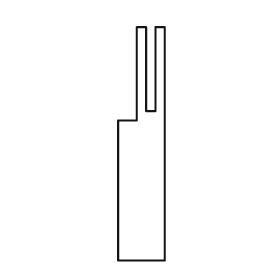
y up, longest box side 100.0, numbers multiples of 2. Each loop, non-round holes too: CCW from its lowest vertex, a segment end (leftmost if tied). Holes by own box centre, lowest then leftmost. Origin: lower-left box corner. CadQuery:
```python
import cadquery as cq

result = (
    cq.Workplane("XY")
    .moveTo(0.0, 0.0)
    .lineTo(20.0, 0.0)
    .lineTo(20.0, 100.0)
    .lineTo(16.0, 100.0)
    .lineTo(16.0, 64.0)
    .lineTo(12.0, 64.0)
    .lineTo(12.0, 100.0)
    .lineTo(8.0, 100.0)
    .lineTo(8.0, 60.0)
    .lineTo(0.0, 60.0)
    .close()
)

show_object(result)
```